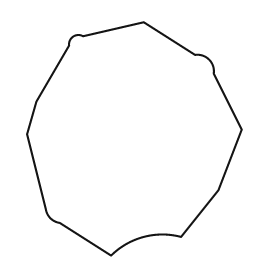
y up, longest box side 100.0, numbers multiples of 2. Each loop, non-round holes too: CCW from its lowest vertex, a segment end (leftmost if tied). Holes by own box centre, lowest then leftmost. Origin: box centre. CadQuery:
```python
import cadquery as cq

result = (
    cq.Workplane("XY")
    .moveTo(-10.0, -50.0)
    .threePointArc((4.0, -42.0), (20.0, -42.0))
    .lineTo(36.0, -22.0)
    .lineTo(46.0, 4.0)
    .lineTo(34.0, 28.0)
    .threePointArc((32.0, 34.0), (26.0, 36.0))
    .lineTo(4.0, 50.0)
    .lineTo(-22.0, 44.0)
    .threePointArc((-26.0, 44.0), (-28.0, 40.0))
    .lineTo(-42.0, 16.0)
    .lineTo(-46.0, 2.0)
    .lineTo(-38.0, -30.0)
    .threePointArc((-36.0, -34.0), (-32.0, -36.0))
    .close()
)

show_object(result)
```